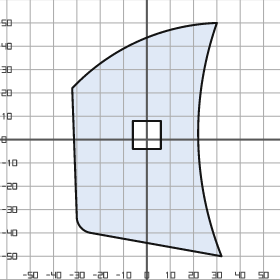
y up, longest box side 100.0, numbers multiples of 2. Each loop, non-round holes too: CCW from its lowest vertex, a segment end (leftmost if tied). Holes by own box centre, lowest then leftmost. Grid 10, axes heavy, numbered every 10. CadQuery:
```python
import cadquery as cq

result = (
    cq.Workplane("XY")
    .moveTo(32.0, -50.0)
    .threePointArc((22.0, 0.0), (30.0, 50.0))
    .threePointArc((-4.0, 42.0), (-32.0, 22.0))
    .lineTo(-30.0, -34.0)
    .threePointArc((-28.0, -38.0), (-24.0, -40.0))
    .close()
    .moveTo(-6.0, -4.0)
    .lineTo(6.0, -4.0)
    .lineTo(6.0, 8.0)
    .lineTo(-6.0, 8.0)
    .close()
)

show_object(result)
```